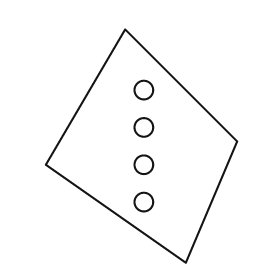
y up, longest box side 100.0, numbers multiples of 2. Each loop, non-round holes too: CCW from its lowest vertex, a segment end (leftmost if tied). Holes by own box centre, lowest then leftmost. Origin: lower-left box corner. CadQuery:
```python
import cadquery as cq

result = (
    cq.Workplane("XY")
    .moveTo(60.0, 0.0)
    .lineTo(82.0, 52.0)
    .lineTo(34.0, 100.0)
    .lineTo(0.0, 42.0)
    .close()
    .moveTo(42.0, 26.0)
    .circle(4.0)
    .moveTo(42.0, 42.0)
    .circle(4.0)
    .moveTo(42.0, 58.0)
    .circle(4.0)
    .moveTo(42.0, 74.0)
    .circle(4.0)
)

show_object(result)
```